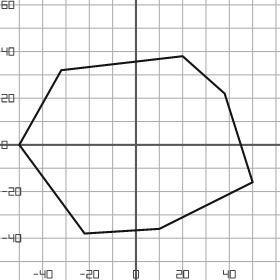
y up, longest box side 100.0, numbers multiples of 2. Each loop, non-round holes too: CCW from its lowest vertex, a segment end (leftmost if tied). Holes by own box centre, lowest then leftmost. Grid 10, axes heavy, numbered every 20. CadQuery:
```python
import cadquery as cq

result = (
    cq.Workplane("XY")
    .moveTo(-22.0, -38.0)
    .lineTo(10.0, -36.0)
    .lineTo(50.0, -16.0)
    .lineTo(38.0, 22.0)
    .lineTo(20.0, 38.0)
    .lineTo(-32.0, 32.0)
    .lineTo(-50.0, 0.0)
    .close()
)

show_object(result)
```